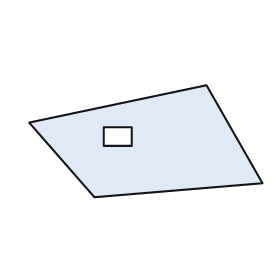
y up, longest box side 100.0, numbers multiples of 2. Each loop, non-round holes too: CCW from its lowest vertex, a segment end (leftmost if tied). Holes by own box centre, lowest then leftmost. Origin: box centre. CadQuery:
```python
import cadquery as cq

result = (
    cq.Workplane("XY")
    .moveTo(-22.0, -24.0)
    .lineTo(50.0, -18.0)
    .lineTo(26.0, 24.0)
    .lineTo(-50.0, 8.0)
    .close()
    .moveTo(-18.0, -2.0)
    .lineTo(-6.0, -2.0)
    .lineTo(-6.0, 6.0)
    .lineTo(-18.0, 6.0)
    .close()
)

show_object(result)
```